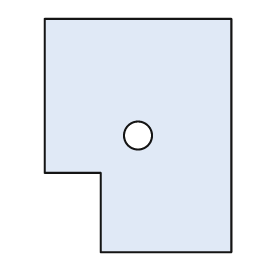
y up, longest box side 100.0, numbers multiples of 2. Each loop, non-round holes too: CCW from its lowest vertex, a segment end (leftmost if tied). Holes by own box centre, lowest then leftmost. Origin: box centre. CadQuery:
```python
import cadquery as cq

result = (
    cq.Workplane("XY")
    .moveTo(-16.0, -50.0)
    .lineTo(40.0, -50.0)
    .lineTo(40.0, 50.0)
    .lineTo(-40.0, 50.0)
    .lineTo(-40.0, -16.0)
    .lineTo(-16.0, -16.0)
    .close()
    .moveTo(0.0, 0.0)
    .circle(6.0)
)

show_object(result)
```